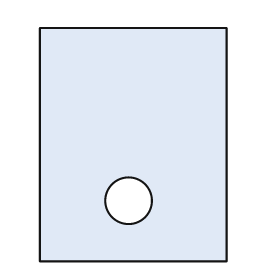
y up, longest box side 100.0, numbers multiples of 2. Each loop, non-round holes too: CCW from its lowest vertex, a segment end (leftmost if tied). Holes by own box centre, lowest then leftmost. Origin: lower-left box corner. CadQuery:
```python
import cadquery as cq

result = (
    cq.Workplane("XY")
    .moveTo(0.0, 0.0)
    .lineTo(80.0, 0.0)
    .lineTo(80.0, 100.0)
    .lineTo(0.0, 100.0)
    .close()
    .moveTo(38.0, 26.0)
    .circle(10.0)
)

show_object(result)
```